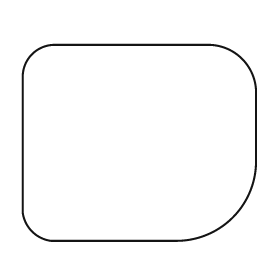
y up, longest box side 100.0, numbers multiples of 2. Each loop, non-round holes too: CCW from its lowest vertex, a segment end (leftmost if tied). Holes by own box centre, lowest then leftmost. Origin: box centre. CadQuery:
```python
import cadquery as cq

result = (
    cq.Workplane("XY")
    .moveTo(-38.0, -42.0)
    .lineTo(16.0, -42.0)
    .threePointArc((40.0, -32.0), (50.0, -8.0))
    .lineTo(50.0, 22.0)
    .threePointArc((44.0, 36.0), (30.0, 42.0))
    .lineTo(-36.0, 42.0)
    .threePointArc((-46.0, 38.0), (-50.0, 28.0))
    .lineTo(-50.0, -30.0)
    .threePointArc((-46.0, -38.0), (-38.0, -42.0))
    .close()
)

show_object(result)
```